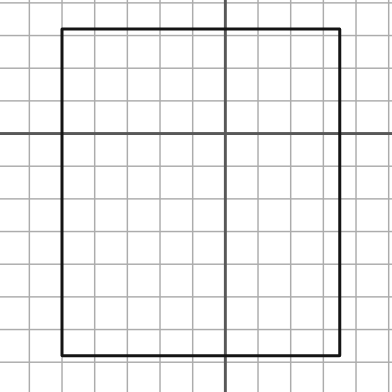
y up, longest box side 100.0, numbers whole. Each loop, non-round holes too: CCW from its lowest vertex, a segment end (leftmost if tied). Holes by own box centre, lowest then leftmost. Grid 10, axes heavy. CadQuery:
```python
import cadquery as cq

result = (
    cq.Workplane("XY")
    .moveTo(-50.0, -68.0)
    .lineTo(35.0, -68.0)
    .lineTo(35.0, 32.0)
    .lineTo(-50.0, 32.0)
    .close()
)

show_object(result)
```